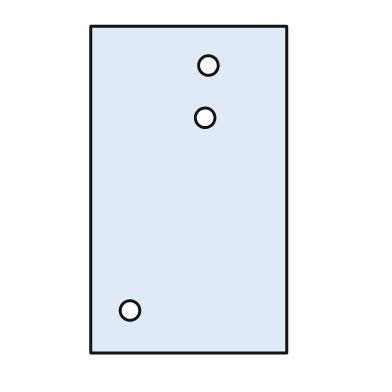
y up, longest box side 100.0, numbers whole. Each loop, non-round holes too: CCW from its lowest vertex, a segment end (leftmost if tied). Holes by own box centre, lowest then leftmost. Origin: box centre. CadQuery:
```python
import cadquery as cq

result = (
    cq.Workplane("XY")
    .moveTo(-30.0, -50.0)
    .lineTo(30.0, -50.0)
    .lineTo(30.0, 50.0)
    .lineTo(-30.0, 50.0)
    .close()
    .moveTo(-18.0, -37.0)
    .circle(3.0)
    .moveTo(5.0, 22.0)
    .circle(3.0)
    .moveTo(6.0, 38.0)
    .circle(3.0)
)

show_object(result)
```